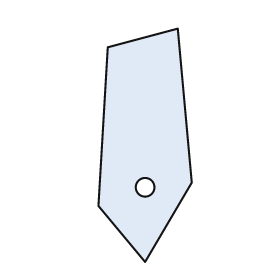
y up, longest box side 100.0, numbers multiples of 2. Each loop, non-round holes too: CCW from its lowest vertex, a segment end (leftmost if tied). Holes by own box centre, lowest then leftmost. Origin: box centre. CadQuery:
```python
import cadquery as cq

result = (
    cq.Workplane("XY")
    .moveTo(0.0, -50.0)
    .lineTo(20.0, -16.0)
    .lineTo(14.0, 50.0)
    .lineTo(-16.0, 42.0)
    .lineTo(-20.0, -26.0)
    .close()
    .moveTo(0.0, -18.0)
    .circle(4.0)
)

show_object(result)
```